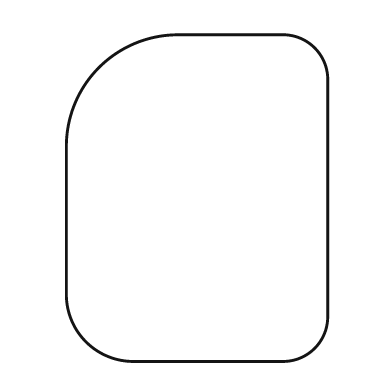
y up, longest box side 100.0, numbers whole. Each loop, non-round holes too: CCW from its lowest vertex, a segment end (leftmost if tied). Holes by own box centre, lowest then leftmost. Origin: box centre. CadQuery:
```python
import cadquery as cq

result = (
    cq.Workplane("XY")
    .moveTo(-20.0, -50.0)
    .lineTo(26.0, -50.0)
    .threePointArc((36.0, -46.0), (40.0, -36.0))
    .lineTo(40.0, 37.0)
    .threePointArc((36.0, 46.0), (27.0, 50.0))
    .lineTo(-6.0, 50.0)
    .threePointArc((-30.0, 40.0), (-40.0, 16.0))
    .lineTo(-40.0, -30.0)
    .threePointArc((-34.0, -44.0), (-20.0, -50.0))
    .close()
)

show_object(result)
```